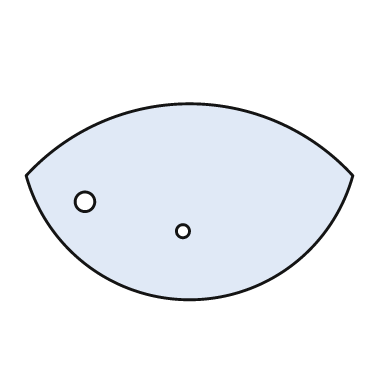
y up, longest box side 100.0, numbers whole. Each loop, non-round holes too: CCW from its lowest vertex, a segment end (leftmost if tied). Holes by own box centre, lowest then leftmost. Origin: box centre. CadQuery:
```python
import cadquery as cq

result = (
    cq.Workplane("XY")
    .moveTo(-50.0, 8.0)
    .threePointArc((0.0, -30.0), (50.0, 8.0))
    .threePointArc((0.0, 30.0), (-50.0, 8.0))
    .close()
    .moveTo(-2.0, -9.0)
    .circle(2.0)
    .moveTo(-32.0, 0.0)
    .circle(3.0)
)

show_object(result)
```